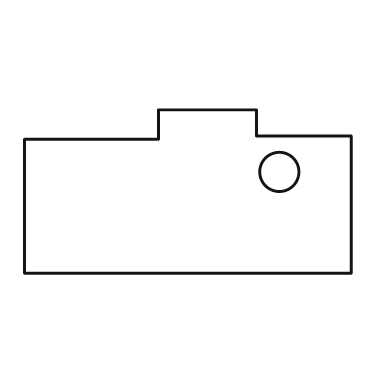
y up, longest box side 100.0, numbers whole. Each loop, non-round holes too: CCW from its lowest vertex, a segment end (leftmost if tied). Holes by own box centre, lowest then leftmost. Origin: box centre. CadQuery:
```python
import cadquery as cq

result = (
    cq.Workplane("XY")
    .moveTo(-50.0, -25.0)
    .lineTo(50.0, -25.0)
    .lineTo(50.0, 17.0)
    .lineTo(21.0, 17.0)
    .lineTo(21.0, 25.0)
    .lineTo(-9.0, 25.0)
    .lineTo(-9.0, 16.0)
    .lineTo(-50.0, 16.0)
    .close()
    .moveTo(28.0, 6.0)
    .circle(6.0)
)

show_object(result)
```